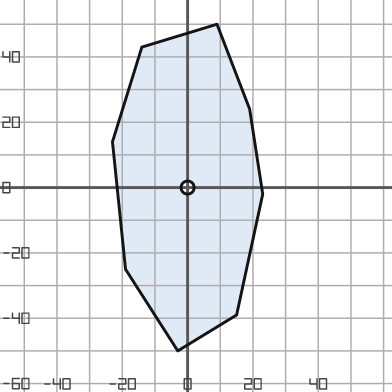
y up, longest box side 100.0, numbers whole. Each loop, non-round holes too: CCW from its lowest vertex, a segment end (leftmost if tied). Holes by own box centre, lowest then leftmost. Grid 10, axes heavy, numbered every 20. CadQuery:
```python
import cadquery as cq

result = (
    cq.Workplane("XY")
    .moveTo(-3.0, -50.0)
    .lineTo(15.0, -39.0)
    .lineTo(23.0, -2.0)
    .lineTo(19.0, 24.0)
    .lineTo(9.0, 50.0)
    .lineTo(-14.0, 43.0)
    .lineTo(-23.0, 14.0)
    .lineTo(-19.0, -25.0)
    .close()
    .moveTo(0.0, 0.0)
    .circle(2.0)
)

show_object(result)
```